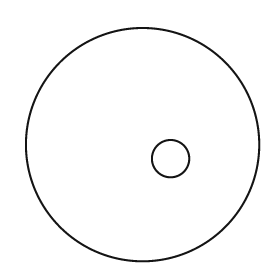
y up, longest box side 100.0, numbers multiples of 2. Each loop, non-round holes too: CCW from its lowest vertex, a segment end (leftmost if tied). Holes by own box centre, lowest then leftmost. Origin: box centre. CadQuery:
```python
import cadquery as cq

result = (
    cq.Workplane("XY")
    .moveTo(0.0, 0.0)
    .circle(50.0)
    .moveTo(12.0, -6.0)
    .circle(8.0)
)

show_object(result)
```